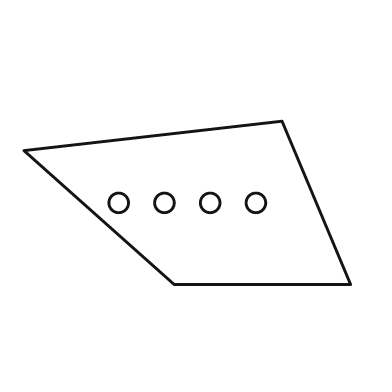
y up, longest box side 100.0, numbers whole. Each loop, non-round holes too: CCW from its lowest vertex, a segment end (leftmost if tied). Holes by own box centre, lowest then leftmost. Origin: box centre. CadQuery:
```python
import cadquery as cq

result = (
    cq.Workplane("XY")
    .moveTo(-4.0, -25.0)
    .lineTo(50.0, -25.0)
    .lineTo(29.0, 25.0)
    .lineTo(-50.0, 16.0)
    .close()
    .moveTo(-21.0, 0.0)
    .circle(3.0)
    .moveTo(-7.0, 0.0)
    .circle(3.0)
    .moveTo(7.0, 0.0)
    .circle(3.0)
    .moveTo(21.0, 0.0)
    .circle(3.0)
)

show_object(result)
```